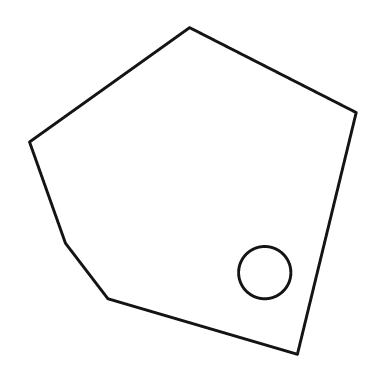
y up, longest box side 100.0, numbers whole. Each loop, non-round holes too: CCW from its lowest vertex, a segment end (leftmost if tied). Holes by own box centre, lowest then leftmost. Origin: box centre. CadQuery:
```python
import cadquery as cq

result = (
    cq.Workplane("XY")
    .moveTo(32.0, -50.0)
    .lineTo(50.0, 24.0)
    .lineTo(-1.0, 50.0)
    .lineTo(-50.0, 15.0)
    .lineTo(-39.0, -16.0)
    .lineTo(-26.0, -33.0)
    .close()
    .moveTo(22.0, -25.0)
    .circle(8.0)
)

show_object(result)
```